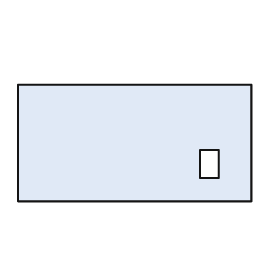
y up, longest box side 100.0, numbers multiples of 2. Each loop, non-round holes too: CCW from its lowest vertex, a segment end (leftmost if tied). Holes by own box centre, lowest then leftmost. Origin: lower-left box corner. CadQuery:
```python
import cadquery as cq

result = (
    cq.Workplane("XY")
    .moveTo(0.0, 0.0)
    .lineTo(100.0, 0.0)
    .lineTo(100.0, 50.0)
    .lineTo(0.0, 50.0)
    .close()
    .moveTo(78.0, 10.0)
    .lineTo(86.0, 10.0)
    .lineTo(86.0, 22.0)
    .lineTo(78.0, 22.0)
    .close()
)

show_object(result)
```